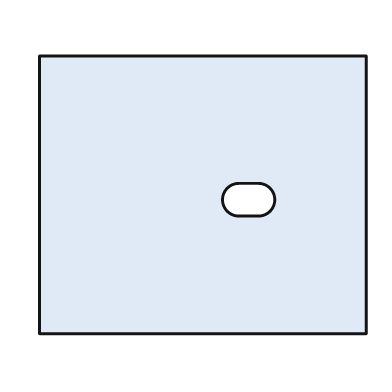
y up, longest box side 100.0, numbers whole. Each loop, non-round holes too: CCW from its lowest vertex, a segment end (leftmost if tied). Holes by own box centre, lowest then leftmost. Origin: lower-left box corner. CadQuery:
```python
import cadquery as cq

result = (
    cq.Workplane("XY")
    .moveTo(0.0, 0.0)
    .lineTo(100.0, 0.0)
    .lineTo(100.0, 85.0)
    .lineTo(0.0, 85.0)
    .close()
    .moveTo(61.0, 36.0)
    .lineTo(67.0, 36.0)
    .threePointArc((72.0, 41.0), (67.0, 46.0))
    .lineTo(61.0, 46.0)
    .threePointArc((56.0, 41.0), (61.0, 36.0))
    .close()
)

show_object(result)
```